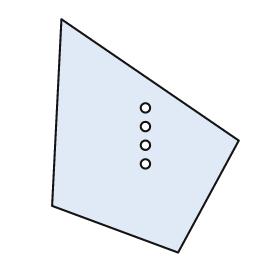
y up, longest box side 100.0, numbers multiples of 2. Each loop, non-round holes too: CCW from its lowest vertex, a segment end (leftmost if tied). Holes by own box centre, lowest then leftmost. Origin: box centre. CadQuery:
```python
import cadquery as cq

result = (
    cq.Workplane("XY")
    .moveTo(14.0, -50.0)
    .lineTo(40.0, -2.0)
    .lineTo(-36.0, 50.0)
    .lineTo(-40.0, -30.0)
    .close()
    .moveTo(0.0, -12.0)
    .circle(2.0)
    .moveTo(0.0, -4.0)
    .circle(2.0)
    .moveTo(0.0, 4.0)
    .circle(2.0)
    .moveTo(0.0, 12.0)
    .circle(2.0)
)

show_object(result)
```